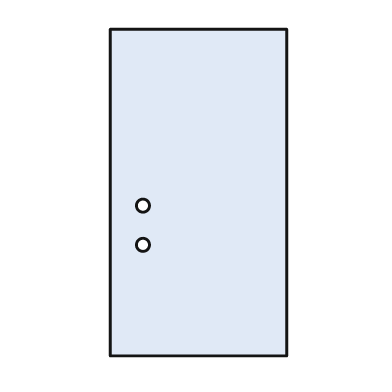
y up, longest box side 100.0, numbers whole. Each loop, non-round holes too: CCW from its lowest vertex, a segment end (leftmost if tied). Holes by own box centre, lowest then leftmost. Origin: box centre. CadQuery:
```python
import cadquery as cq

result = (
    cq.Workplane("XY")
    .moveTo(-27.0, -50.0)
    .lineTo(27.0, -50.0)
    .lineTo(27.0, 50.0)
    .lineTo(-27.0, 50.0)
    .close()
    .moveTo(-17.0, -16.0)
    .circle(2.0)
    .moveTo(-17.0, -4.0)
    .circle(2.0)
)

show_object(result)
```